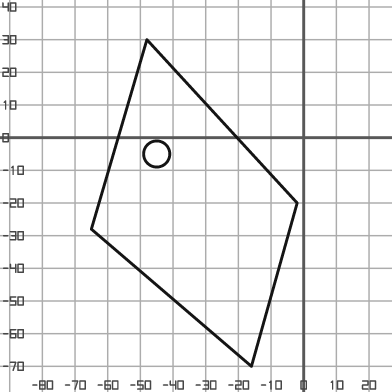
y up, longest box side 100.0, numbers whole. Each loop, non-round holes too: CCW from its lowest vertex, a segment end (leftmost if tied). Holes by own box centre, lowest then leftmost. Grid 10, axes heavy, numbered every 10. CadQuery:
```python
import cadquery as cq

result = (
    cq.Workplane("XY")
    .moveTo(-16.0, -70.0)
    .lineTo(-2.0, -20.0)
    .lineTo(-48.0, 30.0)
    .lineTo(-65.0, -28.0)
    .close()
    .moveTo(-45.0, -5.0)
    .circle(4.0)
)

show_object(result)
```